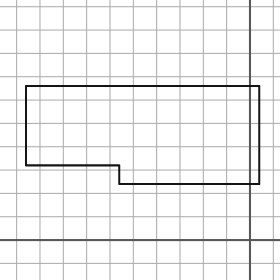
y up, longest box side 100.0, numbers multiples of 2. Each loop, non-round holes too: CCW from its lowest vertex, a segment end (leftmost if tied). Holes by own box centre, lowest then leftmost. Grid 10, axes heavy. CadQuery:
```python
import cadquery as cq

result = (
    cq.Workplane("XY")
    .moveTo(-56.0, 24.0)
    .lineTo(4.0, 24.0)
    .lineTo(4.0, 66.0)
    .lineTo(-96.0, 66.0)
    .lineTo(-96.0, 32.0)
    .lineTo(-56.0, 32.0)
    .close()
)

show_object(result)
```